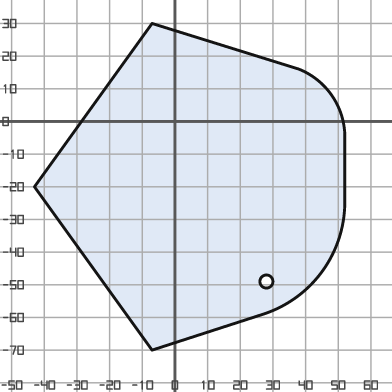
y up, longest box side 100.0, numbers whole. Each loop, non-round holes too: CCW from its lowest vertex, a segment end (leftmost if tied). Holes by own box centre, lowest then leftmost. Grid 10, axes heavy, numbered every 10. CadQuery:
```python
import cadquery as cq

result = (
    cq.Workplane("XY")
    .moveTo(-7.0, -70.0)
    .lineTo(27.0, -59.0)
    .threePointArc((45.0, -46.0), (52.0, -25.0))
    .lineTo(52.0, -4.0)
    .threePointArc((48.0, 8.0), (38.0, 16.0))
    .lineTo(-7.0, 30.0)
    .lineTo(-43.0, -20.0)
    .close()
    .moveTo(28.0, -49.0)
    .circle(2.0)
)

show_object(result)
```